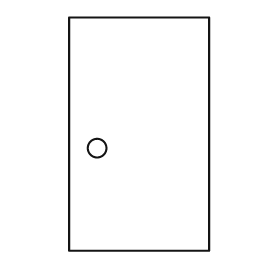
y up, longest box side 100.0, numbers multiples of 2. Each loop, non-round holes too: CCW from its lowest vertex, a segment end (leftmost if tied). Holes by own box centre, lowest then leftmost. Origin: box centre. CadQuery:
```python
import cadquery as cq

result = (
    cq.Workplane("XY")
    .moveTo(-30.0, -50.0)
    .lineTo(30.0, -50.0)
    .lineTo(30.0, 50.0)
    .lineTo(-30.0, 50.0)
    .close()
    .moveTo(-18.0, -6.0)
    .circle(4.0)
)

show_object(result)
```